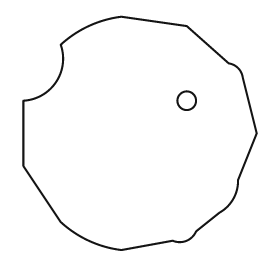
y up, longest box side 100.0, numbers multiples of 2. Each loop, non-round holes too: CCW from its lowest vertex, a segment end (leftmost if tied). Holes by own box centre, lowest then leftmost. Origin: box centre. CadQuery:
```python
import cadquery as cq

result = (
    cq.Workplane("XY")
    .moveTo(-8.0, -50.0)
    .lineTo(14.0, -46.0)
    .threePointArc((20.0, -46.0), (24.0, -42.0))
    .lineTo(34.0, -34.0)
    .threePointArc((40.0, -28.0), (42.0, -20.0))
    .lineTo(50.0, 0.0)
    .lineTo(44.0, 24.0)
    .threePointArc((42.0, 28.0), (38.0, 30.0))
    .lineTo(20.0, 46.0)
    .lineTo(-8.0, 50.0)
    .threePointArc((-22.0, 46.0), (-34.0, 38.0))
    .threePointArc((-36.0, 22.0), (-50.0, 14.0))
    .lineTo(-50.0, -14.0)
    .lineTo(-34.0, -38.0)
    .threePointArc((-22.0, -46.0), (-8.0, -50.0))
    .close()
    .moveTo(20.0, 14.0)
    .circle(4.0)
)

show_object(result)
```